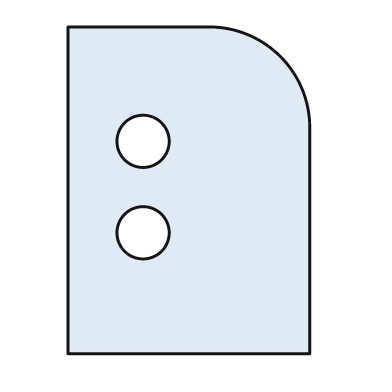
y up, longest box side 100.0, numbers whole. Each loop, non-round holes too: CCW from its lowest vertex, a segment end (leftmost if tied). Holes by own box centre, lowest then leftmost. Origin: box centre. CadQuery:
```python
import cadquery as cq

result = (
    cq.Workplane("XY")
    .moveTo(-37.0, -50.0)
    .lineTo(37.0, -50.0)
    .lineTo(37.0, 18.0)
    .threePointArc((28.0, 41.0), (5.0, 50.0))
    .lineTo(-37.0, 50.0)
    .close()
    .moveTo(-14.0, -13.0)
    .circle(8.0)
    .moveTo(-14.0, 15.0)
    .circle(8.0)
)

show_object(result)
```